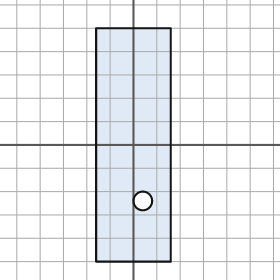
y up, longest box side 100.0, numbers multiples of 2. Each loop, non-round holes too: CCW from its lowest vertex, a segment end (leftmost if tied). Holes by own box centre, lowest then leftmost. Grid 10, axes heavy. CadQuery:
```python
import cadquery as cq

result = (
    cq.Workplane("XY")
    .moveTo(-16.0, -50.0)
    .lineTo(16.0, -50.0)
    .lineTo(16.0, 50.0)
    .lineTo(-16.0, 50.0)
    .close()
    .moveTo(4.0, -24.0)
    .circle(4.0)
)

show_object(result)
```